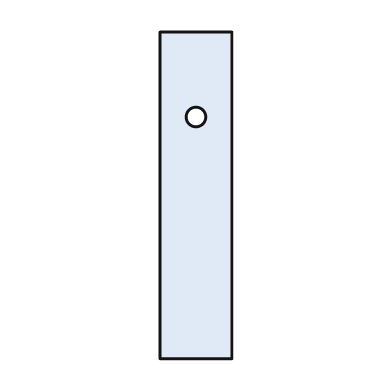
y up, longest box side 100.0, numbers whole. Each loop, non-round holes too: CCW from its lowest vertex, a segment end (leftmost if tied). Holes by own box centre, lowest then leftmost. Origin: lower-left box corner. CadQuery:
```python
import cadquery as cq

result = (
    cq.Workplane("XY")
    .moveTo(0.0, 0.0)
    .lineTo(22.0, 0.0)
    .lineTo(22.0, 100.0)
    .lineTo(0.0, 100.0)
    .close()
    .moveTo(11.0, 74.0)
    .circle(3.0)
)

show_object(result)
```